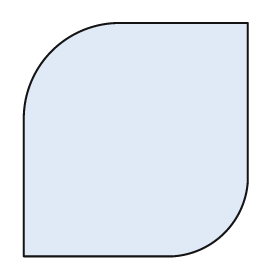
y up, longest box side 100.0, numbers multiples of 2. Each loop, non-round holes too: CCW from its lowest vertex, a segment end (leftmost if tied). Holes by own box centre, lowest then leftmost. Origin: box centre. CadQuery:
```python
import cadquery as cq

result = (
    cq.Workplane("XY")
    .moveTo(-48.0, -50.0)
    .lineTo(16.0, -50.0)
    .threePointArc((38.0, -40.0), (48.0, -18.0))
    .lineTo(48.0, 50.0)
    .lineTo(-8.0, 50.0)
    .threePointArc((-36.0, 38.0), (-48.0, 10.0))
    .close()
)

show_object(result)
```